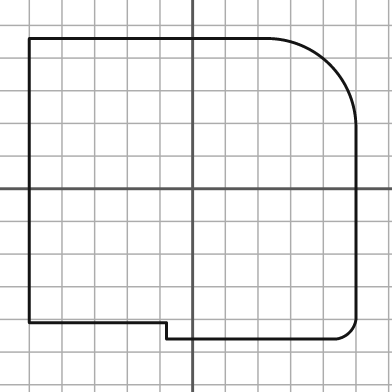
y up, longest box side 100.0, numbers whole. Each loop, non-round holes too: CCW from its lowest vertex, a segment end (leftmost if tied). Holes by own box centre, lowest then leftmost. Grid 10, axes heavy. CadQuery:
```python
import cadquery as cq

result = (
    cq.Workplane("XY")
    .moveTo(-8.0, -46.0)
    .lineTo(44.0, -46.0)
    .threePointArc((48.0, -44.0), (50.0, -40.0))
    .lineTo(50.0, 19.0)
    .threePointArc((42.0, 38.0), (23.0, 46.0))
    .lineTo(-50.0, 46.0)
    .lineTo(-50.0, -41.0)
    .lineTo(-8.0, -41.0)
    .close()
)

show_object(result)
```